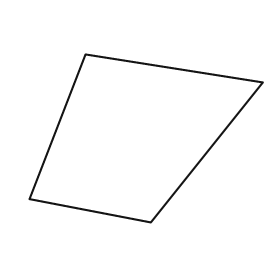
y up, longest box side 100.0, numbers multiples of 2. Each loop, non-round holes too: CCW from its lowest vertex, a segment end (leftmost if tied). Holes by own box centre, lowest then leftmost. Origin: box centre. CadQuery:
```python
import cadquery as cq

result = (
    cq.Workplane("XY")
    .moveTo(2.0, -36.0)
    .lineTo(50.0, 24.0)
    .lineTo(-26.0, 36.0)
    .lineTo(-50.0, -26.0)
    .close()
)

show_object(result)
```